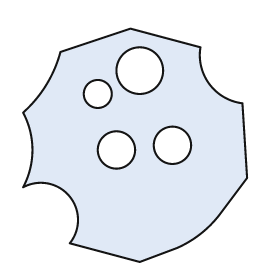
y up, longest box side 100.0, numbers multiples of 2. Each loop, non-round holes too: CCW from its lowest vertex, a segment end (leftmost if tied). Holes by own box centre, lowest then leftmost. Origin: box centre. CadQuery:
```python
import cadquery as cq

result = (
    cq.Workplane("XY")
    .moveTo(2.0, -50.0)
    .lineTo(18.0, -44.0)
    .threePointArc((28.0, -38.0), (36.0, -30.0))
    .lineTo(48.0, -14.0)
    .lineTo(46.0, 18.0)
    .threePointArc((32.0, 26.0), (28.0, 42.0))
    .lineTo(-2.0, 50.0)
    .lineTo(-32.0, 40.0)
    .threePointArc((-38.0, 26.0), (-48.0, 14.0))
    .threePointArc((-44.0, -2.0), (-48.0, -18.0))
    .threePointArc((-28.0, -22.0), (-28.0, -42.0))
    .close()
    .moveTo(-8.0, -2.0)
    .circle(8.0)
    .moveTo(16.0, 0.0)
    .circle(8.0)
    .moveTo(-16.0, 22.0)
    .circle(6.0)
    .moveTo(2.0, 32.0)
    .circle(10.0)
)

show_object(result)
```